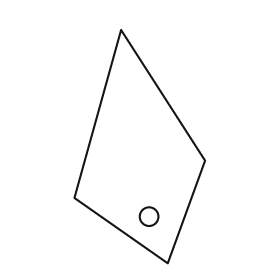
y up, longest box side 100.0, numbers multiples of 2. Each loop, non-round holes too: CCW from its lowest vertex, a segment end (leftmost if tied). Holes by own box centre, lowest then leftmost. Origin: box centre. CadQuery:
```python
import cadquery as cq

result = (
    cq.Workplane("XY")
    .moveTo(12.0, -50.0)
    .lineTo(28.0, -6.0)
    .lineTo(-8.0, 50.0)
    .lineTo(-28.0, -22.0)
    .close()
    .moveTo(4.0, -30.0)
    .circle(4.0)
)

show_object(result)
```